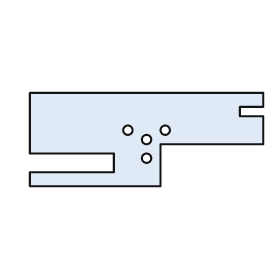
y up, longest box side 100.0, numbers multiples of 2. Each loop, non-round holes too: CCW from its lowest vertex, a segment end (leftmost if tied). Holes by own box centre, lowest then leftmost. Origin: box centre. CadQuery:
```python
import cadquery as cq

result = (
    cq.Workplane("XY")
    .moveTo(-50.0, -20.0)
    .lineTo(6.0, -20.0)
    .lineTo(6.0, -2.0)
    .lineTo(50.0, -2.0)
    .lineTo(50.0, 10.0)
    .lineTo(40.0, 10.0)
    .lineTo(40.0, 14.0)
    .lineTo(50.0, 14.0)
    .lineTo(50.0, 20.0)
    .lineTo(-50.0, 20.0)
    .lineTo(-50.0, -6.0)
    .lineTo(-14.0, -6.0)
    .lineTo(-14.0, -14.0)
    .lineTo(-50.0, -14.0)
    .close()
    .moveTo(0.0, -8.0)
    .circle(2.0)
    .moveTo(0.0, 0.0)
    .circle(2.0)
    .moveTo(-8.0, 4.0)
    .circle(2.0)
    .moveTo(8.0, 4.0)
    .circle(2.0)
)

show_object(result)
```